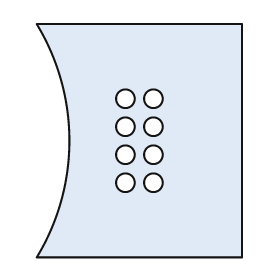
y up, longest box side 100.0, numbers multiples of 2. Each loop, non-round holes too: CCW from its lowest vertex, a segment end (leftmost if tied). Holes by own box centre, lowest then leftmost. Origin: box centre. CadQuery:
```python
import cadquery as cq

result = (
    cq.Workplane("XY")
    .moveTo(-44.0, -50.0)
    .lineTo(44.0, -50.0)
    .lineTo(44.0, 50.0)
    .lineTo(-44.0, 50.0)
    .threePointArc((-30.0, 0.0), (-44.0, -50.0))
    .close()
    .moveTo(-6.0, -18.0)
    .circle(4.0)
    .moveTo(6.0, -18.0)
    .circle(4.0)
    .moveTo(-6.0, -6.0)
    .circle(4.0)
    .moveTo(6.0, -6.0)
    .circle(4.0)
    .moveTo(-6.0, 6.0)
    .circle(4.0)
    .moveTo(6.0, 6.0)
    .circle(4.0)
    .moveTo(-6.0, 18.0)
    .circle(4.0)
    .moveTo(6.0, 18.0)
    .circle(4.0)
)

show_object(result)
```